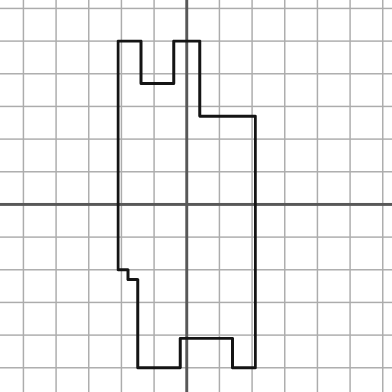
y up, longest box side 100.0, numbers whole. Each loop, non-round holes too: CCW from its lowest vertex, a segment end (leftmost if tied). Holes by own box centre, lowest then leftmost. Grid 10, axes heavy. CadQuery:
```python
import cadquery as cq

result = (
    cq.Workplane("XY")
    .moveTo(-15.0, -50.0)
    .lineTo(-2.0, -50.0)
    .lineTo(-2.0, -41.0)
    .lineTo(14.0, -41.0)
    .lineTo(14.0, -50.0)
    .lineTo(21.0, -50.0)
    .lineTo(21.0, 27.0)
    .lineTo(4.0, 27.0)
    .lineTo(4.0, 50.0)
    .lineTo(-4.0, 50.0)
    .lineTo(-4.0, 37.0)
    .lineTo(-14.0, 37.0)
    .lineTo(-14.0, 50.0)
    .lineTo(-21.0, 50.0)
    .lineTo(-21.0, -20.0)
    .lineTo(-18.0, -20.0)
    .lineTo(-18.0, -23.0)
    .lineTo(-15.0, -23.0)
    .close()
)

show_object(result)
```